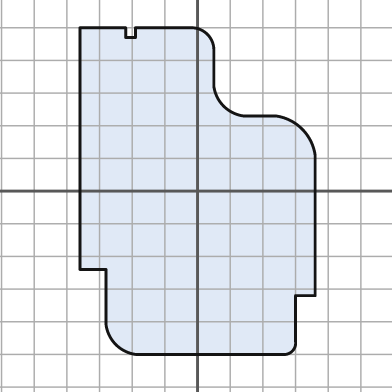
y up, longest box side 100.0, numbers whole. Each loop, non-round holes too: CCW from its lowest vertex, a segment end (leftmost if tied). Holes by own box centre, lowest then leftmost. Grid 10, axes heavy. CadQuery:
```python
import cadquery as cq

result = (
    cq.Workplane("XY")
    .moveTo(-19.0, -50.0)
    .lineTo(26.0, -50.0)
    .threePointArc((29.0, -49.0), (30.0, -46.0))
    .lineTo(30.0, -32.0)
    .lineTo(36.0, -32.0)
    .lineTo(36.0, 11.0)
    .threePointArc((32.0, 19.0), (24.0, 23.0))
    .lineTo(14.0, 23.0)
    .threePointArc((8.0, 26.0), (5.0, 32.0))
    .lineTo(5.0, 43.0)
    .threePointArc((3.0, 48.0), (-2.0, 50.0))
    .lineTo(-19.0, 50.0)
    .lineTo(-19.0, 47.0)
    .lineTo(-22.0, 47.0)
    .lineTo(-22.0, 50.0)
    .lineTo(-36.0, 50.0)
    .lineTo(-36.0, -24.0)
    .lineTo(-28.0, -24.0)
    .lineTo(-28.0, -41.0)
    .threePointArc((-25.0, -47.0), (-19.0, -50.0))
    .close()
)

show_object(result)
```